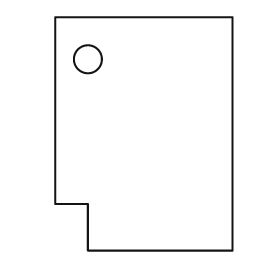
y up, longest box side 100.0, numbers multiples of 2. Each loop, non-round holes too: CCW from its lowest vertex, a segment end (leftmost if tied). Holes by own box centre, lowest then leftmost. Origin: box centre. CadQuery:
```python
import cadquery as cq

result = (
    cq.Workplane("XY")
    .moveTo(-24.0, -50.0)
    .lineTo(38.0, -50.0)
    .lineTo(38.0, 50.0)
    .lineTo(-38.0, 50.0)
    .lineTo(-38.0, -30.0)
    .lineTo(-24.0, -30.0)
    .close()
    .moveTo(-24.0, 32.0)
    .circle(6.0)
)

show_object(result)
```